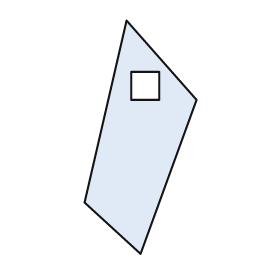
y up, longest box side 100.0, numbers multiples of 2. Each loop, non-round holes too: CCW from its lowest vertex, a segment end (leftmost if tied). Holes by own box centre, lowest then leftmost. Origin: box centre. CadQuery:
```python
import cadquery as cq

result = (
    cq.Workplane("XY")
    .moveTo(0.0, -50.0)
    .lineTo(24.0, 16.0)
    .lineTo(-6.0, 50.0)
    .lineTo(-24.0, -28.0)
    .close()
    .moveTo(-4.0, 16.0)
    .lineTo(8.0, 16.0)
    .lineTo(8.0, 28.0)
    .lineTo(-4.0, 28.0)
    .close()
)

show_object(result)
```